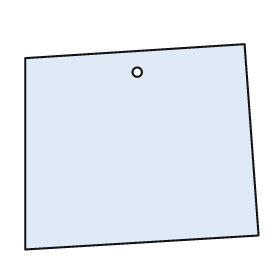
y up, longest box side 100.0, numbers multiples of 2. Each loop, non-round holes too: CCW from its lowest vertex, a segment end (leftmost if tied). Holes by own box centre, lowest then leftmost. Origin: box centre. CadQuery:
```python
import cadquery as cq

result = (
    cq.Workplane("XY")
    .moveTo(-50.0, -44.0)
    .lineTo(50.0, -38.0)
    .lineTo(44.0, 44.0)
    .lineTo(-50.0, 38.0)
    .close()
    .moveTo(-2.0, 32.0)
    .circle(2.0)
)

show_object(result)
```